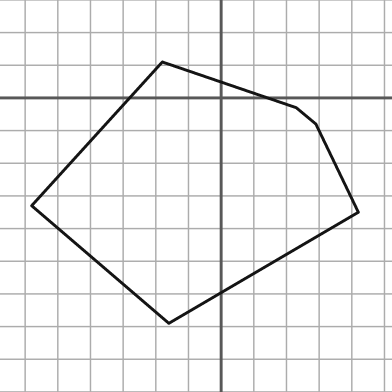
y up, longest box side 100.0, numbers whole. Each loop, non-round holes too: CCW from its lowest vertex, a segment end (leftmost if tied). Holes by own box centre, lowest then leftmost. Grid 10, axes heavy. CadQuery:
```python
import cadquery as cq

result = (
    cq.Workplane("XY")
    .moveTo(-16.0, -69.0)
    .lineTo(42.0, -35.0)
    .lineTo(29.0, -8.0)
    .lineTo(23.0, -3.0)
    .lineTo(-18.0, 11.0)
    .lineTo(-58.0, -33.0)
    .close()
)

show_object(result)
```